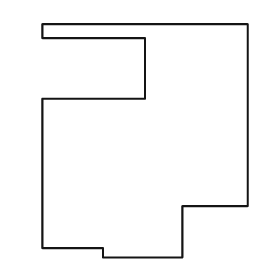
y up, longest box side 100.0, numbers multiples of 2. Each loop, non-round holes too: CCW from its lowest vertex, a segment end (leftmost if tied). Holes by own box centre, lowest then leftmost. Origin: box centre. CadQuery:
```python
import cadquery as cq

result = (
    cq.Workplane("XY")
    .moveTo(-18.0, -50.0)
    .lineTo(16.0, -50.0)
    .lineTo(16.0, -28.0)
    .lineTo(44.0, -28.0)
    .lineTo(44.0, 50.0)
    .lineTo(-44.0, 50.0)
    .lineTo(-44.0, 44.0)
    .lineTo(0.0, 44.0)
    .lineTo(0.0, 18.0)
    .lineTo(-44.0, 18.0)
    .lineTo(-44.0, -46.0)
    .lineTo(-18.0, -46.0)
    .close()
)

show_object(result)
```